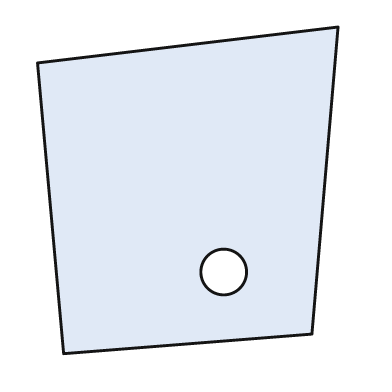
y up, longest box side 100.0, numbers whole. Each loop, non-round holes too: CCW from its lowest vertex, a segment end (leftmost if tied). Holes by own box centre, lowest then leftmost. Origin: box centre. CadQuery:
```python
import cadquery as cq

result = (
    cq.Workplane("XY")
    .moveTo(-38.0, -50.0)
    .lineTo(38.0, -44.0)
    .lineTo(46.0, 50.0)
    .lineTo(-46.0, 39.0)
    .close()
    .moveTo(11.0, -25.0)
    .circle(7.0)
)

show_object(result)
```